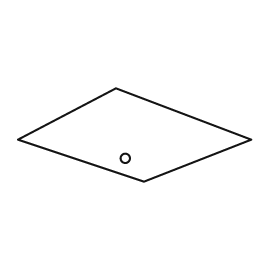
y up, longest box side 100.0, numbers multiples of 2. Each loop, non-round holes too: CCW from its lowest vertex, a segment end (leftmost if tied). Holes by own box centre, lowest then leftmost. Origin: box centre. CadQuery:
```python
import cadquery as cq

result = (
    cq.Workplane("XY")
    .moveTo(4.0, -20.0)
    .lineTo(50.0, -2.0)
    .lineTo(-8.0, 20.0)
    .lineTo(-50.0, -2.0)
    .close()
    .moveTo(-4.0, -10.0)
    .circle(2.0)
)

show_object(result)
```